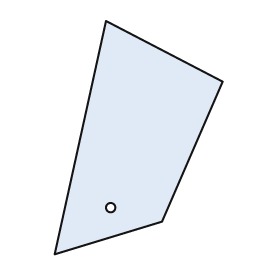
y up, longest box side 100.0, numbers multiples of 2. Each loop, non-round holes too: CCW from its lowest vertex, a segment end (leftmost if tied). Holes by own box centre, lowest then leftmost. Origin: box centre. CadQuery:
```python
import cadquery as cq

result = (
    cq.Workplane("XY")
    .moveTo(-36.0, -50.0)
    .lineTo(10.0, -36.0)
    .lineTo(36.0, 24.0)
    .lineTo(-14.0, 50.0)
    .close()
    .moveTo(-12.0, -30.0)
    .circle(2.0)
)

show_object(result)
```